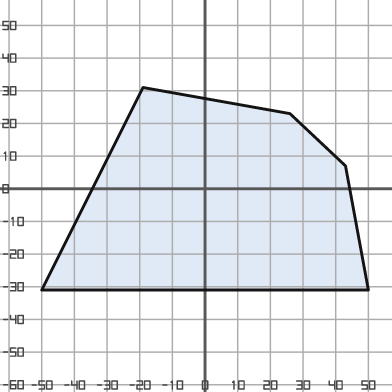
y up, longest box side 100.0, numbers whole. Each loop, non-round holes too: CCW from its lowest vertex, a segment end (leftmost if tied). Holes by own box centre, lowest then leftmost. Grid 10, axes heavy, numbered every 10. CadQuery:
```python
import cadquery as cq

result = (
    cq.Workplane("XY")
    .moveTo(-50.0, -31.0)
    .lineTo(50.0, -31.0)
    .lineTo(43.0, 7.0)
    .lineTo(26.0, 23.0)
    .lineTo(-19.0, 31.0)
    .close()
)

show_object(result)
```